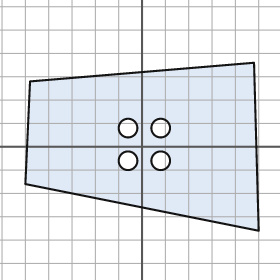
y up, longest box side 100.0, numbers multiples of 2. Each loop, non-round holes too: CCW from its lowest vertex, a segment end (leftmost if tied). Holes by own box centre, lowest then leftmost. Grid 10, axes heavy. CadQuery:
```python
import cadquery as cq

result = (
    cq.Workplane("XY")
    .moveTo(50.0, -36.0)
    .lineTo(48.0, 36.0)
    .lineTo(-48.0, 28.0)
    .lineTo(-50.0, -16.0)
    .close()
    .moveTo(-6.0, -6.0)
    .circle(4.0)
    .moveTo(8.0, -6.0)
    .circle(4.0)
    .moveTo(-6.0, 8.0)
    .circle(4.0)
    .moveTo(8.0, 8.0)
    .circle(4.0)
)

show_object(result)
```